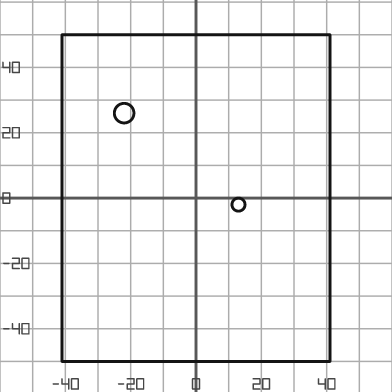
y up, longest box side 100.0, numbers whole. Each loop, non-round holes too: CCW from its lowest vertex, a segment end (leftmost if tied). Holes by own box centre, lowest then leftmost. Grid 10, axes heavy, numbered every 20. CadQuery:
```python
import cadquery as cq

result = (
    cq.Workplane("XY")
    .moveTo(-41.0, -50.0)
    .lineTo(41.0, -50.0)
    .lineTo(41.0, 50.0)
    .lineTo(-41.0, 50.0)
    .close()
    .moveTo(13.0, -2.0)
    .circle(2.0)
    .moveTo(-22.0, 26.0)
    .circle(3.0)
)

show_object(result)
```